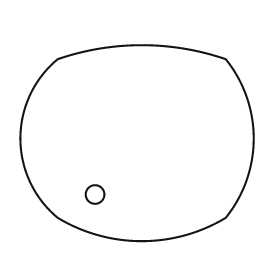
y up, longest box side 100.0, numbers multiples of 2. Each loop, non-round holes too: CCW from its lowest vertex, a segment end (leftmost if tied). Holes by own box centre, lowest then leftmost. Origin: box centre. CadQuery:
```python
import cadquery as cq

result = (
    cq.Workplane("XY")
    .moveTo(-34.0, -32.0)
    .threePointArc((2.0, -42.0), (38.0, -32.0))
    .threePointArc((50.0, 2.0), (38.0, 36.0))
    .threePointArc((2.0, 42.0), (-34.0, 36.0))
    .threePointArc((-50.0, 2.0), (-34.0, -32.0))
    .close()
    .moveTo(-18.0, -22.0)
    .circle(4.0)
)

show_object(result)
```